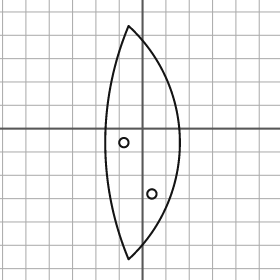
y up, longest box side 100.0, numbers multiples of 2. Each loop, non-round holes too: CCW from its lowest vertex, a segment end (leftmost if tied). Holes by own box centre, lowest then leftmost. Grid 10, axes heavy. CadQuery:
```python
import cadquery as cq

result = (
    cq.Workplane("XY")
    .moveTo(-6.0, -56.0)
    .threePointArc((16.0, -6.0), (-6.0, 44.0))
    .threePointArc((-16.0, -6.0), (-6.0, -56.0))
    .close()
    .moveTo(4.0, -28.0)
    .circle(2.0)
    .moveTo(-8.0, -6.0)
    .circle(2.0)
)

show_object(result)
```